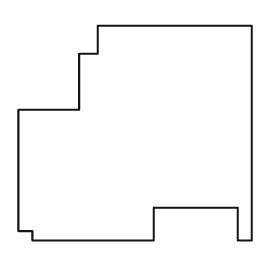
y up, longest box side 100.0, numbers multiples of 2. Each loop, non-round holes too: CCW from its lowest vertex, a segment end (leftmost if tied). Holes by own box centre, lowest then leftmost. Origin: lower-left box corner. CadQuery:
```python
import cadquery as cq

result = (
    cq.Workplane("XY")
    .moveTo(6.0, 0.0)
    .lineTo(58.0, 0.0)
    .lineTo(58.0, 14.0)
    .lineTo(94.0, 14.0)
    .lineTo(94.0, 0.0)
    .lineTo(100.0, 0.0)
    .lineTo(100.0, 92.0)
    .lineTo(34.0, 92.0)
    .lineTo(34.0, 80.0)
    .lineTo(26.0, 80.0)
    .lineTo(26.0, 56.0)
    .lineTo(0.0, 56.0)
    .lineTo(0.0, 4.0)
    .lineTo(6.0, 4.0)
    .close()
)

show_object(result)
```